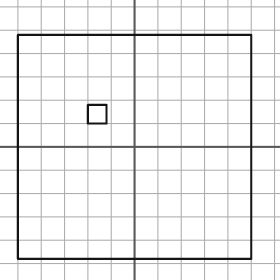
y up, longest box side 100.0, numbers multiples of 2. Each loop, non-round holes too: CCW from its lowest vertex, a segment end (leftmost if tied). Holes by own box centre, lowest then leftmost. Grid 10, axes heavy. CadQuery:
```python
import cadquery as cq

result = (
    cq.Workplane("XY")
    .moveTo(-50.0, -48.0)
    .lineTo(50.0, -48.0)
    .lineTo(50.0, 48.0)
    .lineTo(-50.0, 48.0)
    .close()
    .moveTo(-20.0, 10.0)
    .lineTo(-12.0, 10.0)
    .lineTo(-12.0, 18.0)
    .lineTo(-20.0, 18.0)
    .close()
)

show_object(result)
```